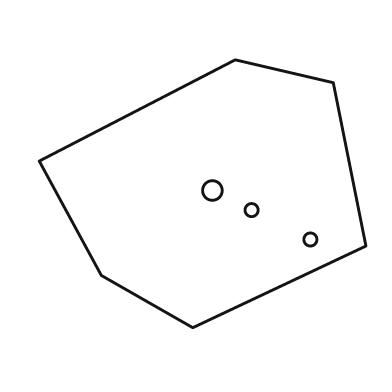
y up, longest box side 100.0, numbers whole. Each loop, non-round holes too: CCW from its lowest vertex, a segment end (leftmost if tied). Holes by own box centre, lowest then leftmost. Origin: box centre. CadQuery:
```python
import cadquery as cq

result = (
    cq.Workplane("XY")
    .moveTo(-3.0, -41.0)
    .lineTo(50.0, -16.0)
    .lineTo(40.0, 34.0)
    .lineTo(10.0, 41.0)
    .lineTo(-50.0, 10.0)
    .lineTo(-31.0, -25.0)
    .close()
    .moveTo(33.0, -14.0)
    .circle(2.0)
    .moveTo(15.0, -5.0)
    .circle(2.0)
    .moveTo(3.0, 1.0)
    .circle(3.0)
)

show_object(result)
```